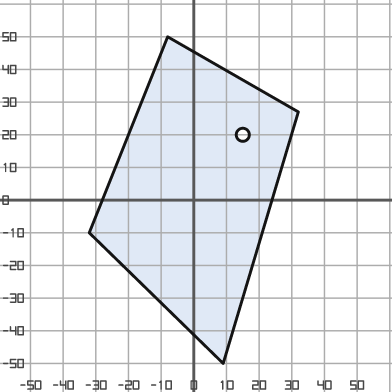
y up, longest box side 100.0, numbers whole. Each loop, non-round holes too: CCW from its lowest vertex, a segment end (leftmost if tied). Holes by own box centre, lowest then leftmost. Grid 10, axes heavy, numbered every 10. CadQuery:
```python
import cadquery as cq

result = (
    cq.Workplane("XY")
    .moveTo(9.0, -50.0)
    .lineTo(32.0, 27.0)
    .lineTo(-8.0, 50.0)
    .lineTo(-32.0, -10.0)
    .close()
    .moveTo(15.0, 20.0)
    .circle(2.0)
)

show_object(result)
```